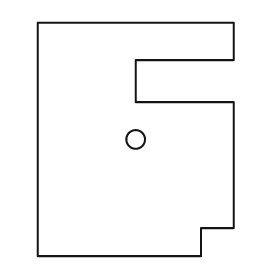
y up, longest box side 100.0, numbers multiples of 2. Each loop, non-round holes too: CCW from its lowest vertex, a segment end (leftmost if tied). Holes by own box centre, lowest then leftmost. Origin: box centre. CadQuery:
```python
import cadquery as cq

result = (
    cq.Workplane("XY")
    .moveTo(-42.0, -50.0)
    .lineTo(28.0, -50.0)
    .lineTo(28.0, -38.0)
    .lineTo(42.0, -38.0)
    .lineTo(42.0, 16.0)
    .lineTo(0.0, 16.0)
    .lineTo(0.0, 34.0)
    .lineTo(42.0, 34.0)
    .lineTo(42.0, 50.0)
    .lineTo(-42.0, 50.0)
    .close()
    .moveTo(0.0, 0.0)
    .circle(4.0)
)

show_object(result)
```